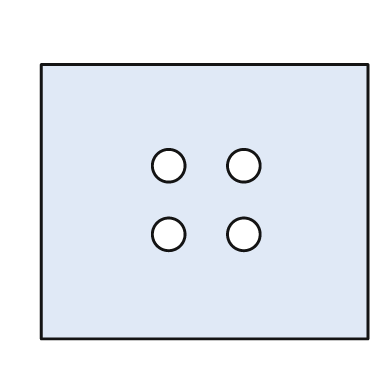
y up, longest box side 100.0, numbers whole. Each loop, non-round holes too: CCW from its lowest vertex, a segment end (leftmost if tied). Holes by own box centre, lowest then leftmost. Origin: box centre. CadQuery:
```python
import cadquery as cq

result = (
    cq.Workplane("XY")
    .moveTo(-50.0, -42.0)
    .lineTo(50.0, -42.0)
    .lineTo(50.0, 42.0)
    .lineTo(-50.0, 42.0)
    .close()
    .moveTo(-11.0, -10.0)
    .circle(5.0)
    .moveTo(12.0, -10.0)
    .circle(5.0)
    .moveTo(-11.0, 11.0)
    .circle(5.0)
    .moveTo(12.0, 11.0)
    .circle(5.0)
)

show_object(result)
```